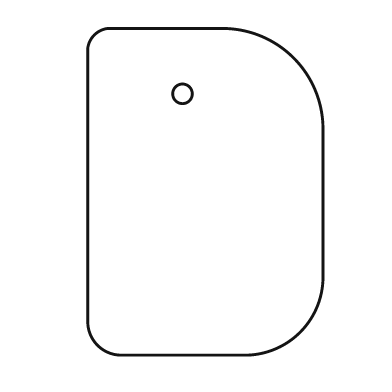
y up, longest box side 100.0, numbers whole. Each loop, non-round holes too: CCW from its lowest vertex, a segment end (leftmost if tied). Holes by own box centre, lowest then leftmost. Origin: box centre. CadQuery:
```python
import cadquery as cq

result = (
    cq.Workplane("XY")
    .moveTo(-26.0, -50.0)
    .lineTo(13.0, -50.0)
    .threePointArc((29.0, -43.0), (36.0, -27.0))
    .lineTo(36.0, 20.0)
    .threePointArc((27.0, 41.0), (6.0, 50.0))
    .lineTo(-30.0, 50.0)
    .threePointArc((-34.0, 48.0), (-36.0, 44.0))
    .lineTo(-36.0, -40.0)
    .threePointArc((-33.0, -47.0), (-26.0, -50.0))
    .close()
    .moveTo(-7.0, 30.0)
    .circle(3.0)
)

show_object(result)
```